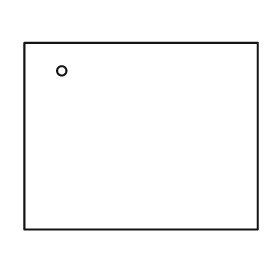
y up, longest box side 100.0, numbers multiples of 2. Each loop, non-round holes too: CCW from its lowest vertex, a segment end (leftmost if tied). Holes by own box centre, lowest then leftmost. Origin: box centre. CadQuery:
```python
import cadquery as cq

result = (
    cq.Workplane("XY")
    .moveTo(-50.0, -40.0)
    .lineTo(50.0, -40.0)
    .lineTo(50.0, 40.0)
    .lineTo(-50.0, 40.0)
    .close()
    .moveTo(-34.0, 28.0)
    .circle(2.0)
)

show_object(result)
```